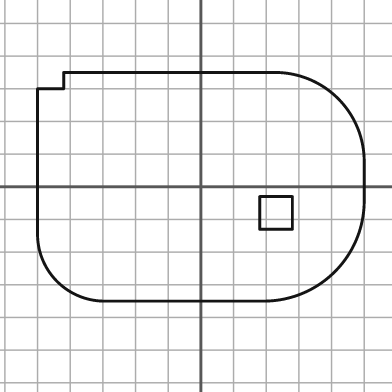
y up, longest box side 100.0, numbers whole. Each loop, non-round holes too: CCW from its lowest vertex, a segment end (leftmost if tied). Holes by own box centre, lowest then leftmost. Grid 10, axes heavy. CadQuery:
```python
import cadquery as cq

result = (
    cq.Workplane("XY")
    .moveTo(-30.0, -35.0)
    .lineTo(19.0, -35.0)
    .threePointArc((41.0, -26.0), (50.0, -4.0))
    .lineTo(50.0, 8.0)
    .threePointArc((42.0, 27.0), (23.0, 35.0))
    .lineTo(-42.0, 35.0)
    .lineTo(-42.0, 30.0)
    .lineTo(-50.0, 30.0)
    .lineTo(-50.0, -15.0)
    .threePointArc((-44.0, -29.0), (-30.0, -35.0))
    .close()
    .moveTo(18.0, -13.0)
    .lineTo(28.0, -13.0)
    .lineTo(28.0, -3.0)
    .lineTo(18.0, -3.0)
    .close()
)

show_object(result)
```